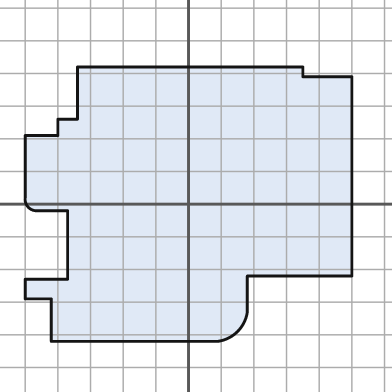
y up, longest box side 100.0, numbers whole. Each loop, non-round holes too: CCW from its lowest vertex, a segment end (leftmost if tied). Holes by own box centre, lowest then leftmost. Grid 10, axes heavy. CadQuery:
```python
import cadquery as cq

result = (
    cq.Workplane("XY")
    .moveTo(-42.0, -42.0)
    .lineTo(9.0, -42.0)
    .threePointArc((15.0, -39.0), (18.0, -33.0))
    .lineTo(18.0, -22.0)
    .lineTo(50.0, -22.0)
    .lineTo(50.0, 39.0)
    .lineTo(35.0, 39.0)
    .lineTo(35.0, 42.0)
    .lineTo(-34.0, 42.0)
    .lineTo(-34.0, 26.0)
    .lineTo(-40.0, 26.0)
    .lineTo(-40.0, 21.0)
    .lineTo(-50.0, 21.0)
    .lineTo(-50.0, 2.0)
    .threePointArc((-49.0, -1.0), (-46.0, -2.0))
    .lineTo(-37.0, -2.0)
    .lineTo(-37.0, -23.0)
    .lineTo(-50.0, -23.0)
    .lineTo(-50.0, -29.0)
    .lineTo(-42.0, -29.0)
    .close()
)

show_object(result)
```